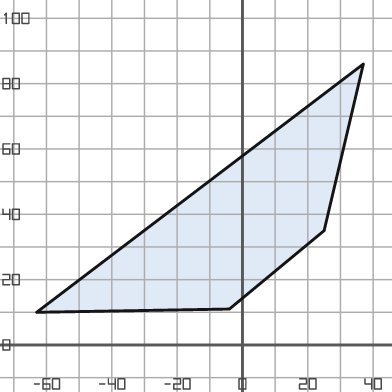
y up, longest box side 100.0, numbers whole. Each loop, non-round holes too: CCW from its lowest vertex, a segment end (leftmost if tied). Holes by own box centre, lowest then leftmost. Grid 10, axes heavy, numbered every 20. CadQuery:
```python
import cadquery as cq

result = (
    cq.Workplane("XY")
    .moveTo(-63.0, 10.0)
    .lineTo(-4.0, 11.0)
    .lineTo(25.0, 35.0)
    .lineTo(37.0, 86.0)
    .close()
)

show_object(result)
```